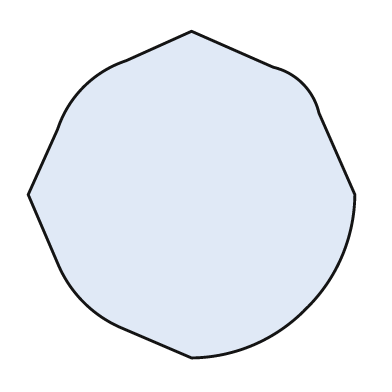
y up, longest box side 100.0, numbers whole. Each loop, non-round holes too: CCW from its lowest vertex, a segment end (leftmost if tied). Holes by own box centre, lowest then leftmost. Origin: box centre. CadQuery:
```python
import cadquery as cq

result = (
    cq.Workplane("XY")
    .moveTo(0.0, -50.0)
    .threePointArc((19.0, -46.0), (35.0, -35.0))
    .threePointArc((46.0, -19.0), (50.0, 0.0))
    .lineTo(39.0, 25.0)
    .threePointArc((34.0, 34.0), (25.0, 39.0))
    .lineTo(0.0, 50.0)
    .lineTo(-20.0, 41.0)
    .threePointArc((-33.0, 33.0), (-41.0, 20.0))
    .lineTo(-50.0, 0.0)
    .lineTo(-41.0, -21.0)
    .threePointArc((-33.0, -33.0), (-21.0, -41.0))
    .close()
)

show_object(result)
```